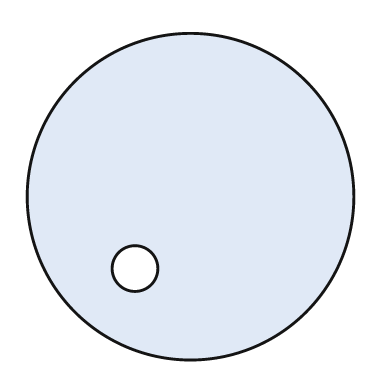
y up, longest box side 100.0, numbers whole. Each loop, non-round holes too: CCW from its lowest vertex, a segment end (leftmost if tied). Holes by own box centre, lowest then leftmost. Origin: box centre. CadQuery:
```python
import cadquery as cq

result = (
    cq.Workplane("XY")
    .moveTo(0.0, 0.0)
    .circle(50.0)
    .moveTo(-17.0, -22.0)
    .circle(7.0)
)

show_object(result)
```